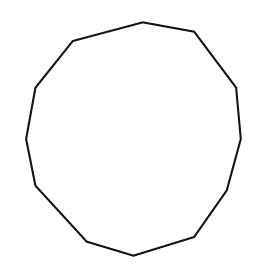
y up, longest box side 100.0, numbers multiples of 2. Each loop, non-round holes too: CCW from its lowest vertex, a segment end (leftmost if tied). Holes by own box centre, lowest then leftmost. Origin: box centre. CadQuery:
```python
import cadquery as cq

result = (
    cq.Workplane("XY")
    .moveTo(0.0, -50.0)
    .lineTo(26.0, -42.0)
    .lineTo(40.0, -22.0)
    .lineTo(46.0, 0.0)
    .lineTo(44.0, 22.0)
    .lineTo(26.0, 46.0)
    .lineTo(4.0, 50.0)
    .lineTo(-26.0, 42.0)
    .lineTo(-42.0, 22.0)
    .lineTo(-46.0, 0.0)
    .lineTo(-42.0, -20.0)
    .lineTo(-20.0, -44.0)
    .close()
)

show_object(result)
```